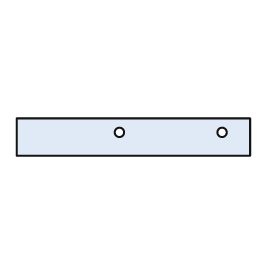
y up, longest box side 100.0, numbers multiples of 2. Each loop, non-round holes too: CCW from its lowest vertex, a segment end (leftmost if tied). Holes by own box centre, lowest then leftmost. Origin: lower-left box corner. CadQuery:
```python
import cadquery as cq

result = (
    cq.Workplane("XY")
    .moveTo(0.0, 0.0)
    .lineTo(100.0, 0.0)
    .lineTo(100.0, 16.0)
    .lineTo(0.0, 16.0)
    .close()
    .moveTo(44.0, 10.0)
    .circle(2.0)
    .moveTo(88.0, 10.0)
    .circle(2.0)
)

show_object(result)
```